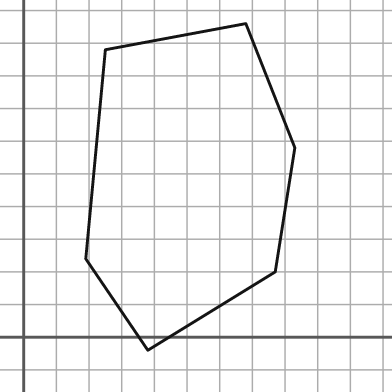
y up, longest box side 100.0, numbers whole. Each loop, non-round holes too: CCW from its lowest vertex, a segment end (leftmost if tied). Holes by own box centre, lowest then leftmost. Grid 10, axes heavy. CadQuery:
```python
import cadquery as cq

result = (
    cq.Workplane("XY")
    .moveTo(38.0, -4.0)
    .lineTo(77.0, 20.0)
    .lineTo(83.0, 58.0)
    .lineTo(68.0, 96.0)
    .lineTo(25.0, 88.0)
    .lineTo(19.0, 24.0)
    .close()
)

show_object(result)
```